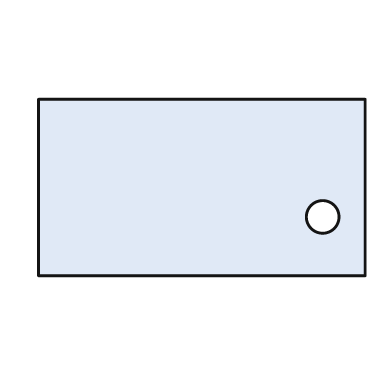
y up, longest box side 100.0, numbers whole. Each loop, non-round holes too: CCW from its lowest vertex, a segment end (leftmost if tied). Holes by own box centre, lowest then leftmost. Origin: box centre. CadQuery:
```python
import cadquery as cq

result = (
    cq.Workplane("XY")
    .moveTo(-50.0, -27.0)
    .lineTo(50.0, -27.0)
    .lineTo(50.0, 27.0)
    .lineTo(-50.0, 27.0)
    .close()
    .moveTo(37.0, -9.0)
    .circle(5.0)
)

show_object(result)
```